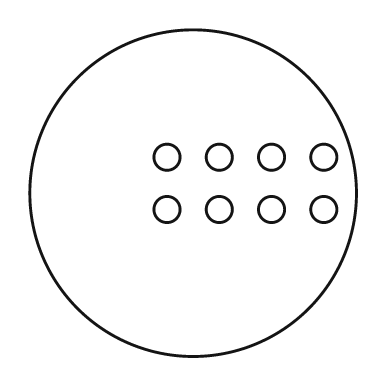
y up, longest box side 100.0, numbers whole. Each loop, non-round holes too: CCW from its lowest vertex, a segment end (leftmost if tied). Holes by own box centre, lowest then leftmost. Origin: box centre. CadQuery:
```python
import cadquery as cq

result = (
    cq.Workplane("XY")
    .moveTo(0.0, 0.0)
    .circle(50.0)
    .moveTo(-8.0, -5.0)
    .circle(4.0)
    .moveTo(8.0, -5.0)
    .circle(4.0)
    .moveTo(24.0, -5.0)
    .circle(4.0)
    .moveTo(40.0, -5.0)
    .circle(4.0)
    .moveTo(-8.0, 11.0)
    .circle(4.0)
    .moveTo(8.0, 11.0)
    .circle(4.0)
    .moveTo(24.0, 11.0)
    .circle(4.0)
    .moveTo(40.0, 11.0)
    .circle(4.0)
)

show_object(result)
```